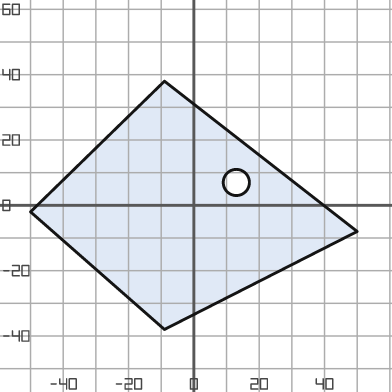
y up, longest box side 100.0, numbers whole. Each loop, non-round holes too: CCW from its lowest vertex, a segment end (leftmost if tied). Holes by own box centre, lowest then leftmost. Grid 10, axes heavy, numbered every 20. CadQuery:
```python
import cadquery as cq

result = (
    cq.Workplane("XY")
    .moveTo(-9.0, -38.0)
    .lineTo(50.0, -8.0)
    .lineTo(-9.0, 38.0)
    .lineTo(-50.0, -2.0)
    .close()
    .moveTo(13.0, 7.0)
    .circle(4.0)
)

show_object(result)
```